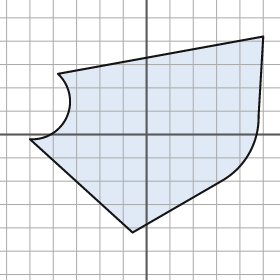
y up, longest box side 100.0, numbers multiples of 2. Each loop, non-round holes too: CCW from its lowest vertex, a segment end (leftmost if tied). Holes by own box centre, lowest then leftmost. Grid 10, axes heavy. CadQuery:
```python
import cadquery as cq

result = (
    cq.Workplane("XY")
    .moveTo(-6.0, -42.0)
    .lineTo(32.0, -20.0)
    .threePointArc((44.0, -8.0), (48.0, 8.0))
    .lineTo(50.0, 42.0)
    .lineTo(-38.0, 26.0)
    .threePointArc((-34.0, 8.0), (-50.0, -2.0))
    .close()
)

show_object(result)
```